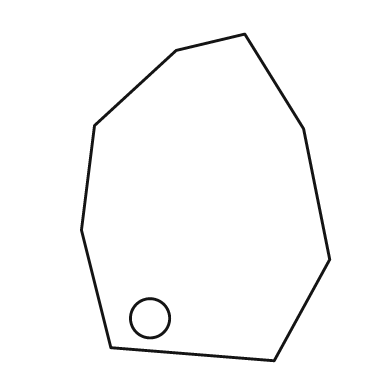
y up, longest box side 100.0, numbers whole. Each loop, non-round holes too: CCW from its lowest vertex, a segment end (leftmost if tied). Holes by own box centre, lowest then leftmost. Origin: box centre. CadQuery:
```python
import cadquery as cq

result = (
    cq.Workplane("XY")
    .moveTo(21.0, -50.0)
    .lineTo(38.0, -19.0)
    .lineTo(30.0, 21.0)
    .lineTo(12.0, 50.0)
    .lineTo(-9.0, 45.0)
    .lineTo(-34.0, 22.0)
    .lineTo(-38.0, -10.0)
    .lineTo(-29.0, -46.0)
    .close()
    .moveTo(-17.0, -37.0)
    .circle(6.0)
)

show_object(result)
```